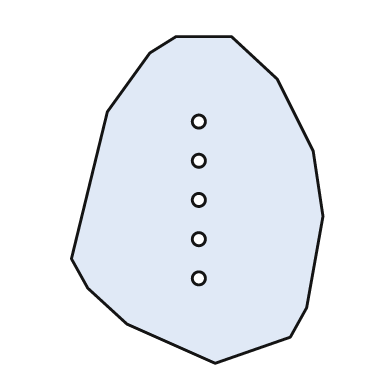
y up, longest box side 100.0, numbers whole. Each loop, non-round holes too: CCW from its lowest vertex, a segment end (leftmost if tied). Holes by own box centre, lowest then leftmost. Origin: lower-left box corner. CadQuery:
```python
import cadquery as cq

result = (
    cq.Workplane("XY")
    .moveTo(44.0, 0.0)
    .lineTo(67.0, 8.0)
    .lineTo(72.0, 17.0)
    .lineTo(77.0, 45.0)
    .lineTo(74.0, 65.0)
    .lineTo(63.0, 87.0)
    .lineTo(49.0, 100.0)
    .lineTo(32.0, 100.0)
    .lineTo(24.0, 95.0)
    .lineTo(11.0, 77.0)
    .lineTo(0.0, 32.0)
    .lineTo(5.0, 23.0)
    .lineTo(17.0, 12.0)
    .close()
    .moveTo(39.0, 26.0)
    .circle(2.0)
    .moveTo(39.0, 38.0)
    .circle(2.0)
    .moveTo(39.0, 50.0)
    .circle(2.0)
    .moveTo(39.0, 62.0)
    .circle(2.0)
    .moveTo(39.0, 74.0)
    .circle(2.0)
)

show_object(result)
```